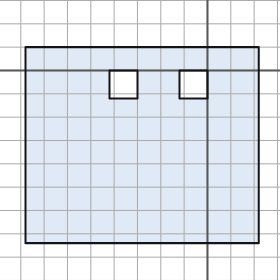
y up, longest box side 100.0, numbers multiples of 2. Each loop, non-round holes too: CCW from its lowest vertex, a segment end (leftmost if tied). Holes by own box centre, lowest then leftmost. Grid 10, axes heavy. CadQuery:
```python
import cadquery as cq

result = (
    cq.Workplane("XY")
    .moveTo(-78.0, -74.0)
    .lineTo(22.0, -74.0)
    .lineTo(22.0, 10.0)
    .lineTo(-78.0, 10.0)
    .close()
    .moveTo(-42.0, -12.0)
    .lineTo(-30.0, -12.0)
    .lineTo(-30.0, 0.0)
    .lineTo(-42.0, 0.0)
    .close()
    .moveTo(-12.0, -12.0)
    .lineTo(0.0, -12.0)
    .lineTo(0.0, 0.0)
    .lineTo(-12.0, 0.0)
    .close()
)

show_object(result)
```